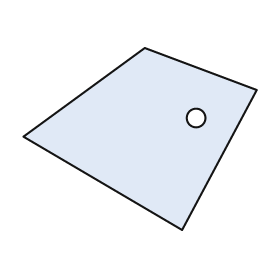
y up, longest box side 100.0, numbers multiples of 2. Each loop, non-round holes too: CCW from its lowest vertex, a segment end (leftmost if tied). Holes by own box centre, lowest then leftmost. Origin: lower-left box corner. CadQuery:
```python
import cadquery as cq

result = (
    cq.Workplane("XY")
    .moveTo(68.0, 0.0)
    .lineTo(100.0, 60.0)
    .lineTo(52.0, 78.0)
    .lineTo(0.0, 40.0)
    .close()
    .moveTo(74.0, 48.0)
    .circle(4.0)
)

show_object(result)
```